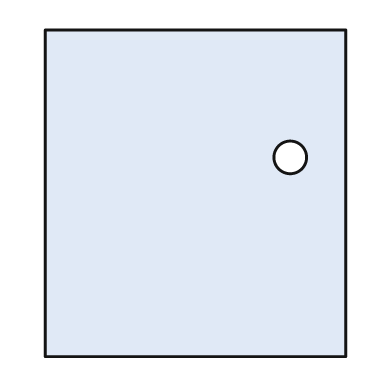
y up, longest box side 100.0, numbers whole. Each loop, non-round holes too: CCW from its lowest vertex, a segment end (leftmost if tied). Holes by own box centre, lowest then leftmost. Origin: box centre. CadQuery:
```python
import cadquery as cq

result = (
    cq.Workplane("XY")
    .moveTo(-46.0, -50.0)
    .lineTo(46.0, -50.0)
    .lineTo(46.0, 50.0)
    .lineTo(-46.0, 50.0)
    .close()
    .moveTo(29.0, 11.0)
    .circle(5.0)
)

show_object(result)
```